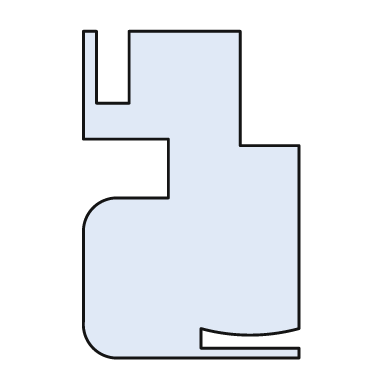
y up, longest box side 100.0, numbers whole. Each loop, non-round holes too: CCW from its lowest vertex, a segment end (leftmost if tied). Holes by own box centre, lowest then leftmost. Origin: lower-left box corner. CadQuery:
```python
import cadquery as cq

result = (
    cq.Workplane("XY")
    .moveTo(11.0, 0.0)
    .lineTo(66.0, 0.0)
    .lineTo(66.0, 3.0)
    .lineTo(36.0, 3.0)
    .lineTo(36.0, 9.0)
    .threePointArc((51.0, 7.0), (66.0, 9.0))
    .lineTo(66.0, 65.0)
    .lineTo(48.0, 65.0)
    .lineTo(48.0, 100.0)
    .lineTo(14.0, 100.0)
    .lineTo(14.0, 78.0)
    .lineTo(4.0, 78.0)
    .lineTo(4.0, 100.0)
    .lineTo(0.0, 100.0)
    .lineTo(0.0, 67.0)
    .lineTo(26.0, 67.0)
    .lineTo(26.0, 49.0)
    .lineTo(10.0, 49.0)
    .threePointArc((3.0, 46.0), (0.0, 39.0))
    .lineTo(0.0, 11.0)
    .threePointArc((3.0, 3.0), (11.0, 0.0))
    .close()
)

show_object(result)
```